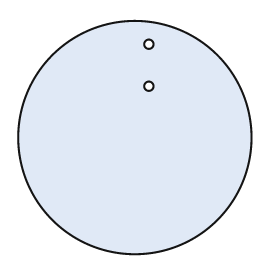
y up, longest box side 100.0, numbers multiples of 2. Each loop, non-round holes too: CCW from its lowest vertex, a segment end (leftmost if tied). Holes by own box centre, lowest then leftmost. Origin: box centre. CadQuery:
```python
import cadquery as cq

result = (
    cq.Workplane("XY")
    .moveTo(0.0, 0.0)
    .circle(50.0)
    .moveTo(6.0, 22.0)
    .circle(2.0)
    .moveTo(6.0, 40.0)
    .circle(2.0)
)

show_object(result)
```